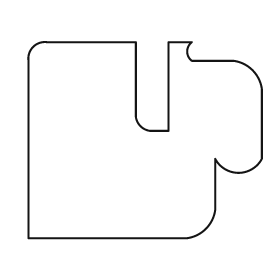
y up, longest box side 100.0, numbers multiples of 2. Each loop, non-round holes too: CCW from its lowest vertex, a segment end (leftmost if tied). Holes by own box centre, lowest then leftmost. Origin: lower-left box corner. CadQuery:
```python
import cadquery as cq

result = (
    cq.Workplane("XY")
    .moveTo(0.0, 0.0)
    .lineTo(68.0, 0.0)
    .threePointArc((76.0, 4.0), (80.0, 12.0))
    .lineTo(80.0, 34.0)
    .threePointArc((90.0, 28.0), (100.0, 34.0))
    .lineTo(100.0, 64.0)
    .threePointArc((96.0, 72.0), (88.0, 76.0))
    .lineTo(70.0, 76.0)
    .threePointArc((68.0, 80.0), (70.0, 84.0))
    .lineTo(60.0, 84.0)
    .lineTo(60.0, 46.0)
    .lineTo(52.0, 46.0)
    .threePointArc((48.0, 48.0), (46.0, 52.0))
    .lineTo(46.0, 84.0)
    .lineTo(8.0, 84.0)
    .threePointArc((2.0, 82.0), (0.0, 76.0))
    .close()
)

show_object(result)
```